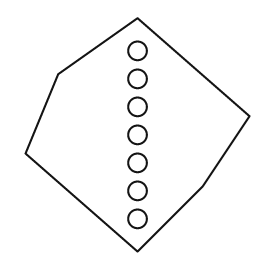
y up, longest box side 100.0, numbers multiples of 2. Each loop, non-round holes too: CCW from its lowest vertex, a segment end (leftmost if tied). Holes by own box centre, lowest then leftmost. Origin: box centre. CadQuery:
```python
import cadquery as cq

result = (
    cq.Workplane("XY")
    .moveTo(0.0, -50.0)
    .lineTo(28.0, -22.0)
    .lineTo(48.0, 8.0)
    .lineTo(0.0, 50.0)
    .lineTo(-34.0, 26.0)
    .lineTo(-48.0, -8.0)
    .close()
    .moveTo(0.0, -36.0)
    .circle(4.0)
    .moveTo(0.0, -24.0)
    .circle(4.0)
    .moveTo(0.0, -12.0)
    .circle(4.0)
    .moveTo(0.0, 0.0)
    .circle(4.0)
    .moveTo(0.0, 12.0)
    .circle(4.0)
    .moveTo(0.0, 24.0)
    .circle(4.0)
    .moveTo(0.0, 36.0)
    .circle(4.0)
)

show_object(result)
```